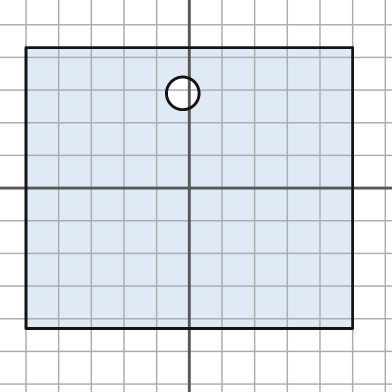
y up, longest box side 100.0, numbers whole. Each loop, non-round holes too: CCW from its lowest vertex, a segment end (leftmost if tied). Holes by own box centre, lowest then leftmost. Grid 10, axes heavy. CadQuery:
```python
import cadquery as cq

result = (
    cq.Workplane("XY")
    .moveTo(-50.0, -43.0)
    .lineTo(50.0, -43.0)
    .lineTo(50.0, 43.0)
    .lineTo(-50.0, 43.0)
    .close()
    .moveTo(-2.0, 29.0)
    .circle(5.0)
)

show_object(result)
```